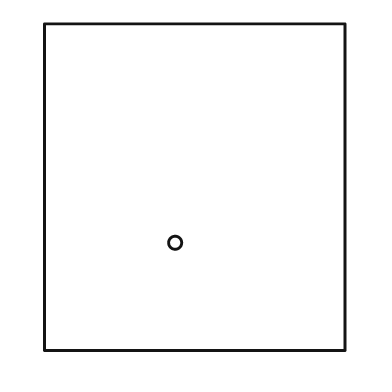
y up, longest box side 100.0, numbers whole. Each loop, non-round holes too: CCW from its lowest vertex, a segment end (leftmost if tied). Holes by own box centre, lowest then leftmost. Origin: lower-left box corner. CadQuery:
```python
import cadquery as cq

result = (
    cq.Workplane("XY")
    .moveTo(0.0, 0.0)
    .lineTo(92.0, 0.0)
    .lineTo(92.0, 100.0)
    .lineTo(0.0, 100.0)
    .close()
    .moveTo(40.0, 33.0)
    .circle(2.0)
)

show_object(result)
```